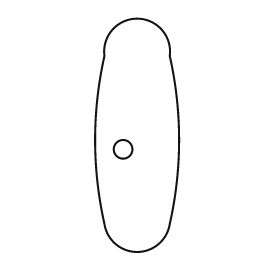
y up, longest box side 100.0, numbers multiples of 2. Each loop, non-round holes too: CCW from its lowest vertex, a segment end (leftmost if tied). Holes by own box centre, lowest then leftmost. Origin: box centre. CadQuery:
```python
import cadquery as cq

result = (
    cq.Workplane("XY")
    .moveTo(-14.0, -38.0)
    .threePointArc((0.0, -50.0), (14.0, -38.0))
    .threePointArc((18.0, -2.0), (14.0, 34.0))
    .threePointArc((0.0, 50.0), (-14.0, 34.0))
    .threePointArc((-18.0, -2.0), (-14.0, -38.0))
    .close()
    .moveTo(-6.0, -6.0)
    .circle(4.0)
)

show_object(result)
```